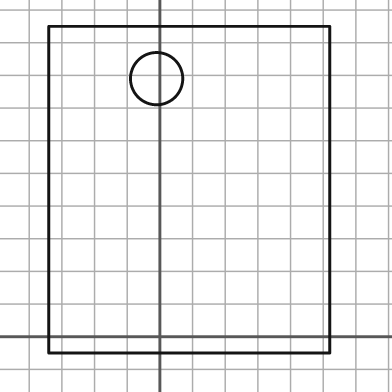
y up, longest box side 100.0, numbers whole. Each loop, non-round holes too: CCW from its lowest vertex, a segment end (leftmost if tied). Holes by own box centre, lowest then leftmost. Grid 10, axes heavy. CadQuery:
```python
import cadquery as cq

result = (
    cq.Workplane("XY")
    .moveTo(-34.0, -5.0)
    .lineTo(52.0, -5.0)
    .lineTo(52.0, 95.0)
    .lineTo(-34.0, 95.0)
    .close()
    .moveTo(-1.0, 79.0)
    .circle(8.0)
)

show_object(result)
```